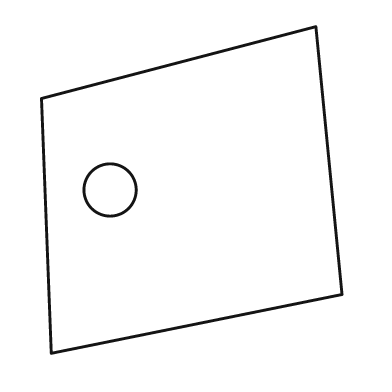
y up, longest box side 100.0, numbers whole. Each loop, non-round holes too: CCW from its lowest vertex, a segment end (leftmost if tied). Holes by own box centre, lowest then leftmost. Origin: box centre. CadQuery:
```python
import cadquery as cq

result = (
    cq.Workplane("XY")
    .moveTo(-43.0, -50.0)
    .lineTo(46.0, -32.0)
    .lineTo(38.0, 50.0)
    .lineTo(-46.0, 28.0)
    .close()
    .moveTo(-25.0, 0.0)
    .circle(8.0)
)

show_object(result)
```